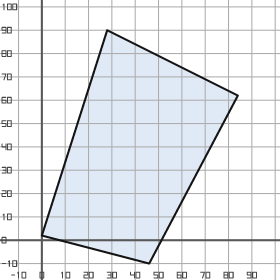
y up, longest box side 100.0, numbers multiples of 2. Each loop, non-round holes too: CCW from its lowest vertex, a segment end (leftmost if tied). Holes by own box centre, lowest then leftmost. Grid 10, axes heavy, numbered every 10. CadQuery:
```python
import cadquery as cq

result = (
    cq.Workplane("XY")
    .moveTo(46.0, -10.0)
    .lineTo(84.0, 62.0)
    .lineTo(28.0, 90.0)
    .lineTo(0.0, 2.0)
    .close()
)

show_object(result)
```